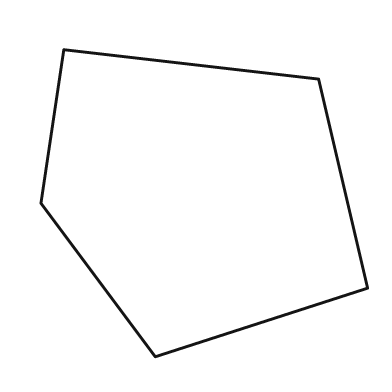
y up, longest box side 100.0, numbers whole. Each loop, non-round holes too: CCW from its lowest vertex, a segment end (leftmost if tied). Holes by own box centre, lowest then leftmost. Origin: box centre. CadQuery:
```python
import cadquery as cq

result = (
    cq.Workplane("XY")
    .moveTo(-15.0, -47.0)
    .lineTo(50.0, -26.0)
    .lineTo(35.0, 38.0)
    .lineTo(-43.0, 47.0)
    .lineTo(-50.0, 0.0)
    .close()
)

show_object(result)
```